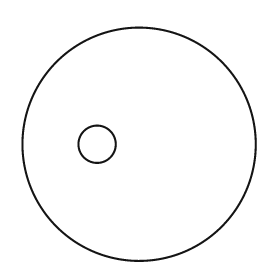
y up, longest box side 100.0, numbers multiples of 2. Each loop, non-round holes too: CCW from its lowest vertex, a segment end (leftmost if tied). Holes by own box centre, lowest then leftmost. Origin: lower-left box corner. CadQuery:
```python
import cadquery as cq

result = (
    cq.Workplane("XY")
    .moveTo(50.0, 50.0)
    .circle(50.0)
    .moveTo(32.0, 50.0)
    .circle(8.0)
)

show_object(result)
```